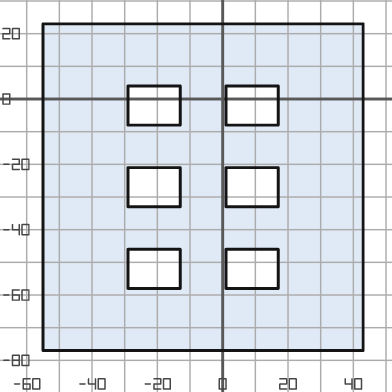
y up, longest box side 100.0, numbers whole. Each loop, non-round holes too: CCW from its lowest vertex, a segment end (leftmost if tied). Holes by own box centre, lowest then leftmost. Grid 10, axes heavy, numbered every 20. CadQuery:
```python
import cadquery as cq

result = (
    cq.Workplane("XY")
    .moveTo(-55.0, -77.0)
    .lineTo(43.0, -77.0)
    .lineTo(43.0, 23.0)
    .lineTo(-55.0, 23.0)
    .close()
    .moveTo(-29.0, -58.0)
    .lineTo(-13.0, -58.0)
    .lineTo(-13.0, -46.0)
    .lineTo(-29.0, -46.0)
    .close()
    .moveTo(1.0, -58.0)
    .lineTo(17.0, -58.0)
    .lineTo(17.0, -46.0)
    .lineTo(1.0, -46.0)
    .close()
    .moveTo(-29.0, -33.0)
    .lineTo(-13.0, -33.0)
    .lineTo(-13.0, -21.0)
    .lineTo(-29.0, -21.0)
    .close()
    .moveTo(1.0, -33.0)
    .lineTo(17.0, -33.0)
    .lineTo(17.0, -21.0)
    .lineTo(1.0, -21.0)
    .close()
    .moveTo(-29.0, -8.0)
    .lineTo(-13.0, -8.0)
    .lineTo(-13.0, 4.0)
    .lineTo(-29.0, 4.0)
    .close()
    .moveTo(1.0, -8.0)
    .lineTo(17.0, -8.0)
    .lineTo(17.0, 4.0)
    .lineTo(1.0, 4.0)
    .close()
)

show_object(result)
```